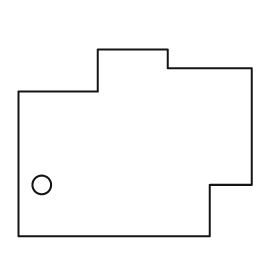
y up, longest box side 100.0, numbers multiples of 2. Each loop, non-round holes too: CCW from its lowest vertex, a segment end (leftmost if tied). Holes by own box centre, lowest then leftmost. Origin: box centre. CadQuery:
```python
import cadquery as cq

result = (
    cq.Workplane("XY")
    .moveTo(-50.0, -40.0)
    .lineTo(32.0, -40.0)
    .lineTo(32.0, -18.0)
    .lineTo(50.0, -18.0)
    .lineTo(50.0, 32.0)
    .lineTo(14.0, 32.0)
    .lineTo(14.0, 40.0)
    .lineTo(-16.0, 40.0)
    .lineTo(-16.0, 22.0)
    .lineTo(-50.0, 22.0)
    .close()
    .moveTo(-40.0, -18.0)
    .circle(4.0)
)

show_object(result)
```